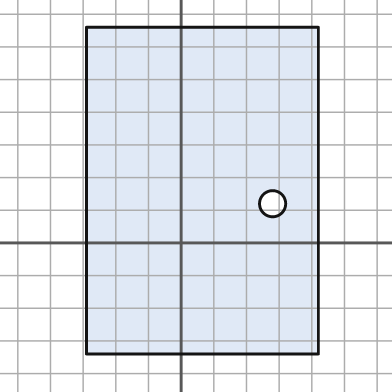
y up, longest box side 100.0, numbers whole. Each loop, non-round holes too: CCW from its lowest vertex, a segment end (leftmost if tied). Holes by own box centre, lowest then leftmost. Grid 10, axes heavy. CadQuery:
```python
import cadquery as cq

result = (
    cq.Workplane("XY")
    .moveTo(-29.0, -34.0)
    .lineTo(42.0, -34.0)
    .lineTo(42.0, 66.0)
    .lineTo(-29.0, 66.0)
    .close()
    .moveTo(28.0, 12.0)
    .circle(4.0)
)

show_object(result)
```